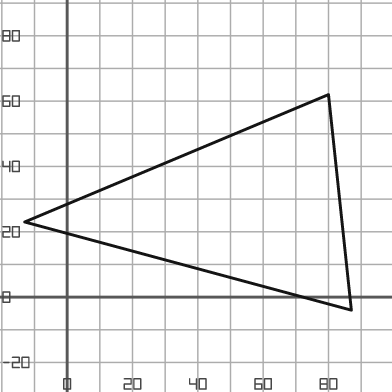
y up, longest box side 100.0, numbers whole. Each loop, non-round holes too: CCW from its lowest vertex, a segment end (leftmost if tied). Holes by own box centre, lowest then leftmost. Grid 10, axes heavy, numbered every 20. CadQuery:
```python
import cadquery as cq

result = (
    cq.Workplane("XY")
    .moveTo(87.0, -4.0)
    .lineTo(80.0, 62.0)
    .lineTo(-13.0, 23.0)
    .close()
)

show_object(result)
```